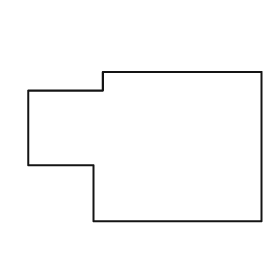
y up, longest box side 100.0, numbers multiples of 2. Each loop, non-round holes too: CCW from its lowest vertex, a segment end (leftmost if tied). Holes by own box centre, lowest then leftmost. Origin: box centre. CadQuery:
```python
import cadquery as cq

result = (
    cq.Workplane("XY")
    .moveTo(-22.0, -32.0)
    .lineTo(50.0, -32.0)
    .lineTo(50.0, 32.0)
    .lineTo(-18.0, 32.0)
    .lineTo(-18.0, 24.0)
    .lineTo(-50.0, 24.0)
    .lineTo(-50.0, -8.0)
    .lineTo(-22.0, -8.0)
    .close()
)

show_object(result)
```